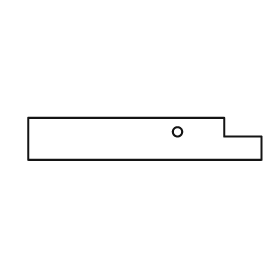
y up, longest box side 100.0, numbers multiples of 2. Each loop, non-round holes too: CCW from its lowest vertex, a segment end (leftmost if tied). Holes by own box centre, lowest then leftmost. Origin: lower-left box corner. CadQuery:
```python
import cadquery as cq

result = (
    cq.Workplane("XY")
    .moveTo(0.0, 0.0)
    .lineTo(100.0, 0.0)
    .lineTo(100.0, 10.0)
    .lineTo(84.0, 10.0)
    .lineTo(84.0, 18.0)
    .lineTo(0.0, 18.0)
    .close()
    .moveTo(64.0, 12.0)
    .circle(2.0)
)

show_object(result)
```